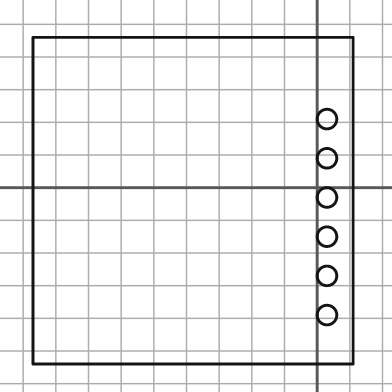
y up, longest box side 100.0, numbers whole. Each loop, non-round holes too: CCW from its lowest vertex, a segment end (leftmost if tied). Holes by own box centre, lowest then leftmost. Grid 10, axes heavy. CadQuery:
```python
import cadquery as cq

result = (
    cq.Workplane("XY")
    .moveTo(-87.0, -54.0)
    .lineTo(11.0, -54.0)
    .lineTo(11.0, 46.0)
    .lineTo(-87.0, 46.0)
    .close()
    .moveTo(3.0, -39.0)
    .circle(3.0)
    .moveTo(3.0, -27.0)
    .circle(3.0)
    .moveTo(3.0, -15.0)
    .circle(3.0)
    .moveTo(3.0, -3.0)
    .circle(3.0)
    .moveTo(3.0, 9.0)
    .circle(3.0)
    .moveTo(3.0, 21.0)
    .circle(3.0)
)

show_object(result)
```